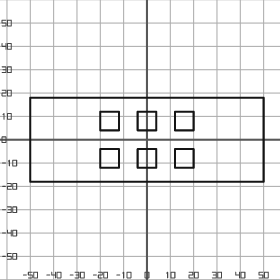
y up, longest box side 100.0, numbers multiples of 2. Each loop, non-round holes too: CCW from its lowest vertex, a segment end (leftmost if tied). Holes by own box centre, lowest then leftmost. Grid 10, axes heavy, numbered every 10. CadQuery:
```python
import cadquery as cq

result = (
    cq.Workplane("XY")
    .moveTo(-50.0, -18.0)
    .lineTo(50.0, -18.0)
    .lineTo(50.0, 18.0)
    .lineTo(-50.0, 18.0)
    .close()
    .moveTo(-20.0, -12.0)
    .lineTo(-12.0, -12.0)
    .lineTo(-12.0, -4.0)
    .lineTo(-20.0, -4.0)
    .close()
    .moveTo(-4.0, -12.0)
    .lineTo(4.0, -12.0)
    .lineTo(4.0, -4.0)
    .lineTo(-4.0, -4.0)
    .close()
    .moveTo(12.0, -12.0)
    .lineTo(20.0, -12.0)
    .lineTo(20.0, -4.0)
    .lineTo(12.0, -4.0)
    .close()
    .moveTo(-20.0, 4.0)
    .lineTo(-12.0, 4.0)
    .lineTo(-12.0, 12.0)
    .lineTo(-20.0, 12.0)
    .close()
    .moveTo(-4.0, 4.0)
    .lineTo(4.0, 4.0)
    .lineTo(4.0, 12.0)
    .lineTo(-4.0, 12.0)
    .close()
    .moveTo(12.0, 4.0)
    .lineTo(20.0, 4.0)
    .lineTo(20.0, 12.0)
    .lineTo(12.0, 12.0)
    .close()
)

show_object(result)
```